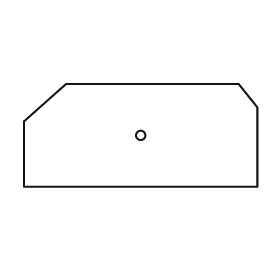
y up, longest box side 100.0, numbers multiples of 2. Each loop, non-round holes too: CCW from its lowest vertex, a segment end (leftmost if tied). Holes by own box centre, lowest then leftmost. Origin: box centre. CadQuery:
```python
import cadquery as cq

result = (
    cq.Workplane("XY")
    .moveTo(-50.0, -22.0)
    .lineTo(50.0, -22.0)
    .lineTo(50.0, 12.0)
    .lineTo(42.0, 22.0)
    .lineTo(-32.0, 22.0)
    .lineTo(-50.0, 6.0)
    .close()
    .moveTo(0.0, 0.0)
    .circle(2.0)
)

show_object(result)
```